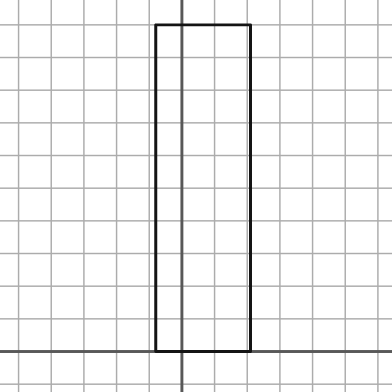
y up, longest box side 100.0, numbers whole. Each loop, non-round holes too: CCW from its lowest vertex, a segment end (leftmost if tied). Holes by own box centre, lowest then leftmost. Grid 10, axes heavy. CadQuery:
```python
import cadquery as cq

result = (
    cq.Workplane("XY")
    .moveTo(-8.0, 0.0)
    .lineTo(21.0, 0.0)
    .lineTo(21.0, 100.0)
    .lineTo(-8.0, 100.0)
    .close()
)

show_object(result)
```